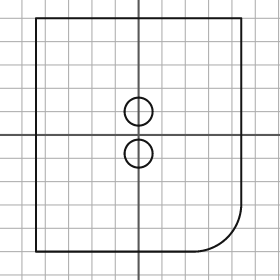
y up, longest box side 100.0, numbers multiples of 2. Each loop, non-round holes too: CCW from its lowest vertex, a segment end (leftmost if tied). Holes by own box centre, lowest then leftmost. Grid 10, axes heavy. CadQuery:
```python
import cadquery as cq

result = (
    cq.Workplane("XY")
    .moveTo(-44.0, -50.0)
    .lineTo(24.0, -50.0)
    .threePointArc((38.0, -44.0), (44.0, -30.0))
    .lineTo(44.0, 50.0)
    .lineTo(-44.0, 50.0)
    .close()
    .moveTo(0.0, -8.0)
    .circle(6.0)
    .moveTo(0.0, 10.0)
    .circle(6.0)
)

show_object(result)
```